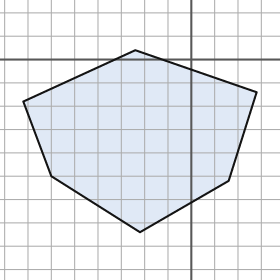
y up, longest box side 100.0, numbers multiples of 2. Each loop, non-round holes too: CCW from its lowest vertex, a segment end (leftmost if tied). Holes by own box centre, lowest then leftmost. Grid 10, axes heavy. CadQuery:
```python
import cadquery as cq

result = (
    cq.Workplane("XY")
    .moveTo(-22.0, -74.0)
    .lineTo(16.0, -52.0)
    .lineTo(28.0, -14.0)
    .lineTo(-24.0, 4.0)
    .lineTo(-72.0, -18.0)
    .lineTo(-60.0, -50.0)
    .close()
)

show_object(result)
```